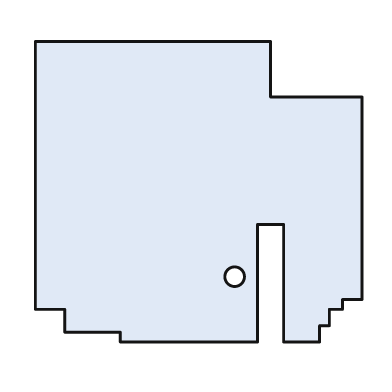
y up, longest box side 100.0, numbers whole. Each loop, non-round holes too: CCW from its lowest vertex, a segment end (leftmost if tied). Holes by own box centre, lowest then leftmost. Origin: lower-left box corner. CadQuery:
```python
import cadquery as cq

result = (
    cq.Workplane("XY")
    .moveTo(26.0, 0.0)
    .lineTo(68.0, 0.0)
    .lineTo(68.0, 36.0)
    .lineTo(76.0, 36.0)
    .lineTo(76.0, 0.0)
    .lineTo(87.0, 0.0)
    .lineTo(87.0, 5.0)
    .lineTo(90.0, 5.0)
    .lineTo(90.0, 10.0)
    .lineTo(94.0, 10.0)
    .lineTo(94.0, 13.0)
    .lineTo(100.0, 13.0)
    .lineTo(100.0, 75.0)
    .lineTo(72.0, 75.0)
    .lineTo(72.0, 92.0)
    .lineTo(0.0, 92.0)
    .lineTo(0.0, 10.0)
    .lineTo(9.0, 10.0)
    .lineTo(9.0, 3.0)
    .lineTo(26.0, 3.0)
    .close()
    .moveTo(61.0, 20.0)
    .circle(3.0)
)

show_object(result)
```